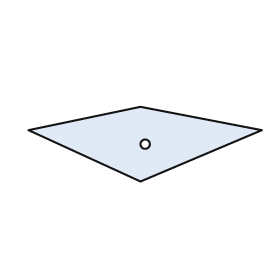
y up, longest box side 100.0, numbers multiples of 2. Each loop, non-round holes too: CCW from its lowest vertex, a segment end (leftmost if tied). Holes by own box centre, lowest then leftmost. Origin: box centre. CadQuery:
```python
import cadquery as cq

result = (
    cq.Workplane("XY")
    .moveTo(-2.0, -16.0)
    .lineTo(50.0, 6.0)
    .lineTo(-2.0, 16.0)
    .lineTo(-50.0, 6.0)
    .close()
    .moveTo(0.0, 0.0)
    .circle(2.0)
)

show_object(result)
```